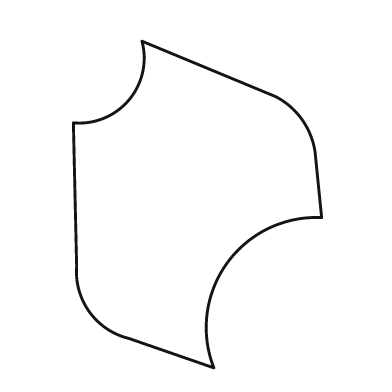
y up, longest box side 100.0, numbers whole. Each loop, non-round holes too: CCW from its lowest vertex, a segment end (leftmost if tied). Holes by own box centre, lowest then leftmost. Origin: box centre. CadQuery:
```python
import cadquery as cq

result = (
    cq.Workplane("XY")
    .moveTo(5.0, -50.0)
    .threePointArc((9.0, -18.0), (38.0, -4.0))
    .lineTo(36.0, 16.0)
    .threePointArc((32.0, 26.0), (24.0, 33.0))
    .lineTo(-17.0, 50.0)
    .threePointArc((-21.0, 32.0), (-38.0, 25.0))
    .lineTo(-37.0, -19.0)
    .threePointArc((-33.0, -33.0), (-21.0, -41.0))
    .close()
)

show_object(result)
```